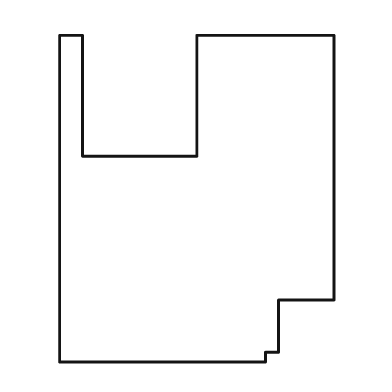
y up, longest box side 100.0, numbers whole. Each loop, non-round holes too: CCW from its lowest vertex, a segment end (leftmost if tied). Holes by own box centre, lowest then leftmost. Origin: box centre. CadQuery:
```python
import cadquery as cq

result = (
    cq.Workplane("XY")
    .moveTo(-42.0, -50.0)
    .lineTo(21.0, -50.0)
    .lineTo(21.0, -47.0)
    .lineTo(25.0, -47.0)
    .lineTo(25.0, -31.0)
    .lineTo(42.0, -31.0)
    .lineTo(42.0, 50.0)
    .lineTo(0.0, 50.0)
    .lineTo(0.0, 13.0)
    .lineTo(-35.0, 13.0)
    .lineTo(-35.0, 50.0)
    .lineTo(-42.0, 50.0)
    .close()
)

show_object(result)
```